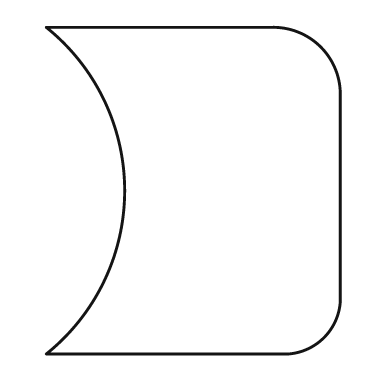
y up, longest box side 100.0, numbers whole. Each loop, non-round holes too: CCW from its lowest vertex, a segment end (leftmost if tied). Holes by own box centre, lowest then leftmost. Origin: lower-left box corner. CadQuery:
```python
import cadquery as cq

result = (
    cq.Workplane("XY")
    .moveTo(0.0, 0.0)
    .lineTo(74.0, 0.0)
    .threePointArc((85.0, 5.0), (90.0, 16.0))
    .lineTo(90.0, 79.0)
    .threePointArc((84.0, 94.0), (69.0, 100.0))
    .lineTo(0.0, 100.0)
    .threePointArc((24.0, 50.0), (0.0, 0.0))
    .close()
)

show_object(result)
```